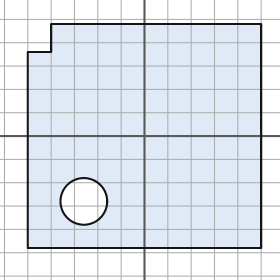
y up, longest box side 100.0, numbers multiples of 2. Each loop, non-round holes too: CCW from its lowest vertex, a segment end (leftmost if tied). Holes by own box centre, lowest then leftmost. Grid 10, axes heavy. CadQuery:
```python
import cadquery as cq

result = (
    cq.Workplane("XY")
    .moveTo(-50.0, -48.0)
    .lineTo(50.0, -48.0)
    .lineTo(50.0, 48.0)
    .lineTo(-40.0, 48.0)
    .lineTo(-40.0, 36.0)
    .lineTo(-50.0, 36.0)
    .close()
    .moveTo(-26.0, -28.0)
    .circle(10.0)
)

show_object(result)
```